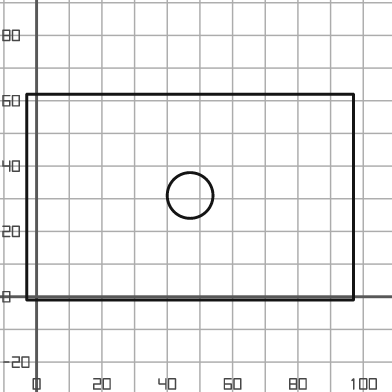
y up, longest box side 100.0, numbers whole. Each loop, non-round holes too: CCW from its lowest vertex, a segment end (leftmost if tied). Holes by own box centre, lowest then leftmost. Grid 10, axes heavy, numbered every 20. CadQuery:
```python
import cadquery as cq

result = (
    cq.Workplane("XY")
    .moveTo(-3.0, -1.0)
    .lineTo(97.0, -1.0)
    .lineTo(97.0, 62.0)
    .lineTo(-3.0, 62.0)
    .close()
    .moveTo(47.0, 31.0)
    .circle(7.0)
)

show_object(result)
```